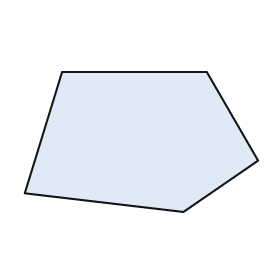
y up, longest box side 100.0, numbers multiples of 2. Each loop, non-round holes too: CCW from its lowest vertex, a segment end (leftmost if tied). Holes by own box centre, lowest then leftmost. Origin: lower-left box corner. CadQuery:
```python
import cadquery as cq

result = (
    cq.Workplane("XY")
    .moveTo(68.0, 0.0)
    .lineTo(100.0, 22.0)
    .lineTo(78.0, 60.0)
    .lineTo(16.0, 60.0)
    .lineTo(0.0, 8.0)
    .close()
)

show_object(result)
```